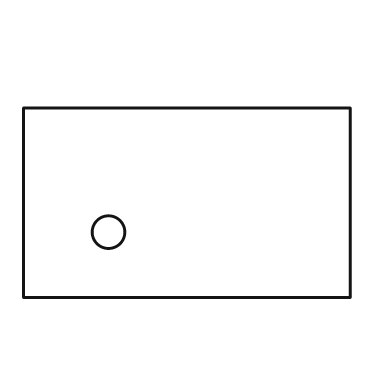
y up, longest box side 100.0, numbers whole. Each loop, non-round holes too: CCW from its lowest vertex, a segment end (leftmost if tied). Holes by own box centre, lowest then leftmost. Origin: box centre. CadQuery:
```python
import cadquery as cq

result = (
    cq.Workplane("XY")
    .moveTo(-50.0, -29.0)
    .lineTo(50.0, -29.0)
    .lineTo(50.0, 29.0)
    .lineTo(-50.0, 29.0)
    .close()
    .moveTo(-24.0, -9.0)
    .circle(5.0)
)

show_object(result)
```